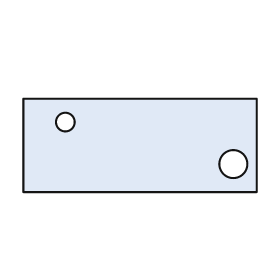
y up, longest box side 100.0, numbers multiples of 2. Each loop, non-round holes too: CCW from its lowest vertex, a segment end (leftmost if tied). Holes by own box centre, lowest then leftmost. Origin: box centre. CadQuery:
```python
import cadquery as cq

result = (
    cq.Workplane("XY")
    .moveTo(-50.0, -20.0)
    .lineTo(50.0, -20.0)
    .lineTo(50.0, 20.0)
    .lineTo(-50.0, 20.0)
    .close()
    .moveTo(40.0, -8.0)
    .circle(6.0)
    .moveTo(-32.0, 10.0)
    .circle(4.0)
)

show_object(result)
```